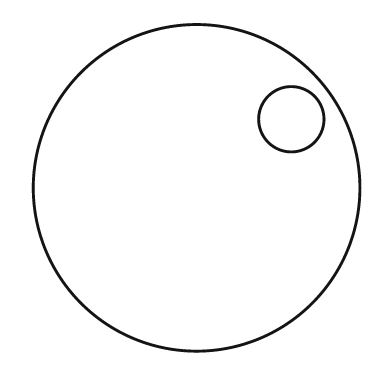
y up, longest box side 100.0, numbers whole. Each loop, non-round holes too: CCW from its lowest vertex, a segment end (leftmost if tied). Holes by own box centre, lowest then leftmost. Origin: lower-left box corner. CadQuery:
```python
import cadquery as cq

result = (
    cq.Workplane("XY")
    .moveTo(50.0, 50.0)
    .circle(50.0)
    .moveTo(79.0, 71.0)
    .circle(10.0)
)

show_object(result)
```